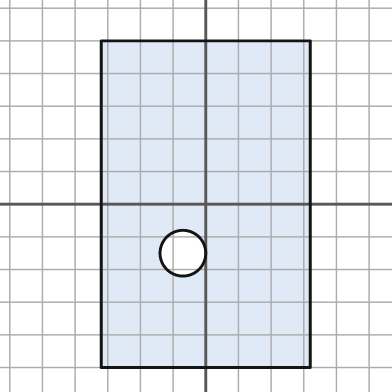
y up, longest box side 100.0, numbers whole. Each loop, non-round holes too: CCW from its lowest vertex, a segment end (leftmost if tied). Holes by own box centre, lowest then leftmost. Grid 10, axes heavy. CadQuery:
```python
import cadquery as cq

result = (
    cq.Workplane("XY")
    .moveTo(-32.0, -50.0)
    .lineTo(32.0, -50.0)
    .lineTo(32.0, 50.0)
    .lineTo(-32.0, 50.0)
    .close()
    .moveTo(-7.0, -15.0)
    .circle(7.0)
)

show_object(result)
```